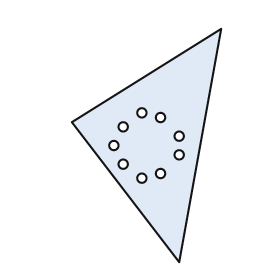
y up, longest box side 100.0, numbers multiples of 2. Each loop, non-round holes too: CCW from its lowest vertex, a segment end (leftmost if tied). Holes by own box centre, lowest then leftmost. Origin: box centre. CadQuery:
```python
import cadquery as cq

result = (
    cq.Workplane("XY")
    .moveTo(14.0, -50.0)
    .lineTo(32.0, 50.0)
    .lineTo(-32.0, 10.0)
    .close()
    .moveTo(-2.0, -14.0)
    .circle(2.0)
    .moveTo(6.0, -12.0)
    .circle(2.0)
    .moveTo(-10.0, -8.0)
    .circle(2.0)
    .moveTo(14.0, -4.0)
    .circle(2.0)
    .moveTo(-14.0, 0.0)
    .circle(2.0)
    .moveTo(14.0, 4.0)
    .circle(2.0)
    .moveTo(-10.0, 8.0)
    .circle(2.0)
    .moveTo(6.0, 12.0)
    .circle(2.0)
    .moveTo(-2.0, 14.0)
    .circle(2.0)
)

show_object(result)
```